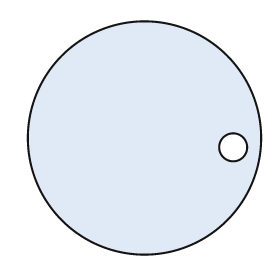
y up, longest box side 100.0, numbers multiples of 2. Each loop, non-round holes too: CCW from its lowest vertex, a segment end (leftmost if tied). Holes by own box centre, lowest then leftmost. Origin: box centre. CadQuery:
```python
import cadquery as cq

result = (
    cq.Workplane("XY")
    .moveTo(0.0, 0.0)
    .circle(50.0)
    .moveTo(38.0, -4.0)
    .circle(6.0)
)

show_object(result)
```